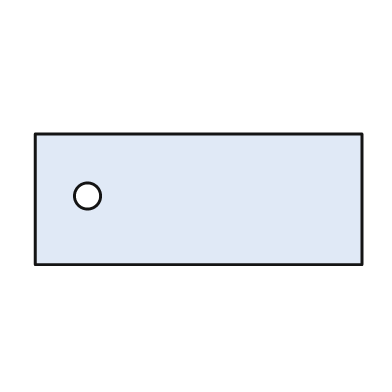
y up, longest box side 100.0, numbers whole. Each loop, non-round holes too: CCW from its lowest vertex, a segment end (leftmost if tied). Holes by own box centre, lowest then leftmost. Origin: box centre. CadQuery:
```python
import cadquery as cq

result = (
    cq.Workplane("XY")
    .moveTo(-50.0, -20.0)
    .lineTo(50.0, -20.0)
    .lineTo(50.0, 20.0)
    .lineTo(-50.0, 20.0)
    .close()
    .moveTo(-34.0, 1.0)
    .circle(4.0)
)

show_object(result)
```